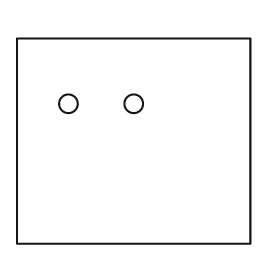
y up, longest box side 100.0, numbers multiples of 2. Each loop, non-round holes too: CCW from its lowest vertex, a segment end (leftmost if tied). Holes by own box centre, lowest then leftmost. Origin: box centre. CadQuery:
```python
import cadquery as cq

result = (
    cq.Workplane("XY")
    .moveTo(-50.0, -44.0)
    .lineTo(50.0, -44.0)
    .lineTo(50.0, 44.0)
    .lineTo(-50.0, 44.0)
    .close()
    .moveTo(-28.0, 16.0)
    .circle(4.0)
    .moveTo(0.0, 16.0)
    .circle(4.0)
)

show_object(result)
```